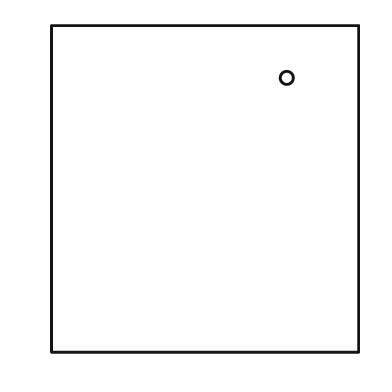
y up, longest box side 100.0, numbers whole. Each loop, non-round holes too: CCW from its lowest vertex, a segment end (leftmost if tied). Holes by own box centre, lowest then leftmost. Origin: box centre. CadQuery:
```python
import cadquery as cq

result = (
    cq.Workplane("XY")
    .moveTo(-47.0, -50.0)
    .lineTo(47.0, -50.0)
    .lineTo(47.0, 50.0)
    .lineTo(-47.0, 50.0)
    .close()
    .moveTo(25.0, 34.0)
    .circle(2.0)
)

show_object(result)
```